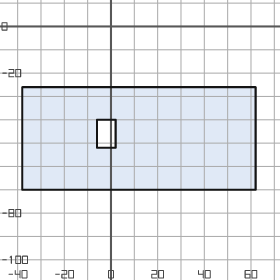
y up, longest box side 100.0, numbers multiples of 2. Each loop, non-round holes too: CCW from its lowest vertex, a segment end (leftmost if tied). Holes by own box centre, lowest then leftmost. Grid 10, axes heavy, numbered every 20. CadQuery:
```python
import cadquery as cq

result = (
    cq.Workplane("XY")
    .moveTo(-38.0, -70.0)
    .lineTo(62.0, -70.0)
    .lineTo(62.0, -26.0)
    .lineTo(-38.0, -26.0)
    .close()
    .moveTo(-6.0, -52.0)
    .lineTo(2.0, -52.0)
    .lineTo(2.0, -40.0)
    .lineTo(-6.0, -40.0)
    .close()
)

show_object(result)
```